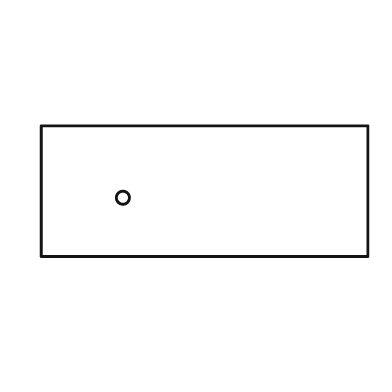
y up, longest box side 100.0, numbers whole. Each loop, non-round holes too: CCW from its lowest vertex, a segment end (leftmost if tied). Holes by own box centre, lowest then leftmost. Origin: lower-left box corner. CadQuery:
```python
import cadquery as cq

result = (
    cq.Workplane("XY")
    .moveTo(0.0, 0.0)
    .lineTo(100.0, 0.0)
    .lineTo(100.0, 40.0)
    .lineTo(0.0, 40.0)
    .close()
    .moveTo(25.0, 18.0)
    .circle(2.0)
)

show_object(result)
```